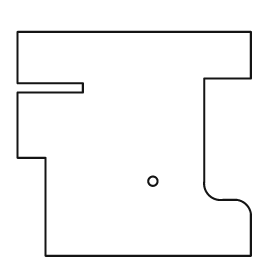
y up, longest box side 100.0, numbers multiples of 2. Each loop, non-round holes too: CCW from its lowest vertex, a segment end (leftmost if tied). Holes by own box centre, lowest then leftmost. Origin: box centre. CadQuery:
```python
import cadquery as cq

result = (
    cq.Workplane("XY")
    .moveTo(-38.0, -48.0)
    .lineTo(50.0, -48.0)
    .lineTo(50.0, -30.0)
    .threePointArc((48.0, -26.0), (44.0, -24.0))
    .lineTo(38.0, -24.0)
    .threePointArc((32.0, -22.0), (30.0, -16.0))
    .lineTo(30.0, 28.0)
    .lineTo(50.0, 28.0)
    .lineTo(50.0, 48.0)
    .lineTo(-50.0, 48.0)
    .lineTo(-50.0, 26.0)
    .lineTo(-22.0, 26.0)
    .lineTo(-22.0, 22.0)
    .lineTo(-50.0, 22.0)
    .lineTo(-50.0, -6.0)
    .lineTo(-38.0, -6.0)
    .close()
    .moveTo(8.0, -16.0)
    .circle(2.0)
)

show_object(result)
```